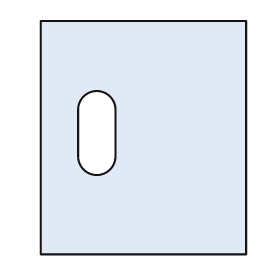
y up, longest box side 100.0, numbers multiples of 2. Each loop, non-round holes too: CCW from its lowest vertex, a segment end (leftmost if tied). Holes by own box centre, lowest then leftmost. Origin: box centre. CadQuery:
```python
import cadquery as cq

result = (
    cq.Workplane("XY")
    .moveTo(-44.0, -50.0)
    .lineTo(44.0, -50.0)
    .lineTo(44.0, 50.0)
    .lineTo(-44.0, 50.0)
    .close()
    .moveTo(-28.0, -8.0)
    .threePointArc((-20.0, -16.0), (-12.0, -8.0))
    .lineTo(-12.0, 12.0)
    .threePointArc((-20.0, 20.0), (-28.0, 12.0))
    .close()
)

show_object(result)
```